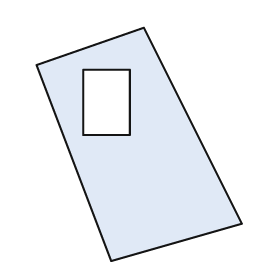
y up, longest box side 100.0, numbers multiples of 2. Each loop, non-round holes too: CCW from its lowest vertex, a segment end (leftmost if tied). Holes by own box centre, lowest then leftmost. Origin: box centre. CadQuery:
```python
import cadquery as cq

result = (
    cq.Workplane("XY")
    .moveTo(-12.0, -50.0)
    .lineTo(44.0, -34.0)
    .lineTo(2.0, 50.0)
    .lineTo(-44.0, 34.0)
    .close()
    .moveTo(-24.0, 4.0)
    .lineTo(-4.0, 4.0)
    .lineTo(-4.0, 32.0)
    .lineTo(-24.0, 32.0)
    .close()
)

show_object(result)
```